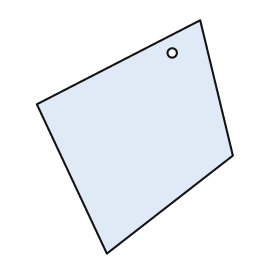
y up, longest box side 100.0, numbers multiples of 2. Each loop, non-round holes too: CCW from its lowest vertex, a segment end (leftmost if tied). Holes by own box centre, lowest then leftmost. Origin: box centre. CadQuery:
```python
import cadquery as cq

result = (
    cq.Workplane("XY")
    .moveTo(-12.0, -50.0)
    .lineTo(42.0, -8.0)
    .lineTo(28.0, 50.0)
    .lineTo(-42.0, 14.0)
    .close()
    .moveTo(16.0, 36.0)
    .circle(2.0)
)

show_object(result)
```